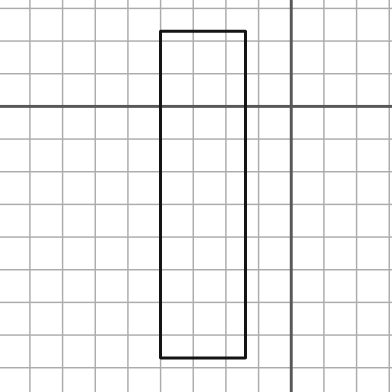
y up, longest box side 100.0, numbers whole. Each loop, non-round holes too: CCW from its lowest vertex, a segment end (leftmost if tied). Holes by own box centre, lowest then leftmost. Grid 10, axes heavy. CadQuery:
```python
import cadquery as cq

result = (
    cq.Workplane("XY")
    .moveTo(-40.0, -77.0)
    .lineTo(-14.0, -77.0)
    .lineTo(-14.0, 23.0)
    .lineTo(-40.0, 23.0)
    .close()
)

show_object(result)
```